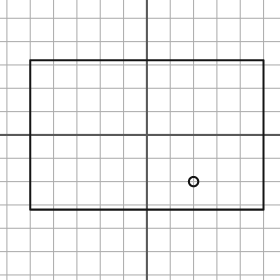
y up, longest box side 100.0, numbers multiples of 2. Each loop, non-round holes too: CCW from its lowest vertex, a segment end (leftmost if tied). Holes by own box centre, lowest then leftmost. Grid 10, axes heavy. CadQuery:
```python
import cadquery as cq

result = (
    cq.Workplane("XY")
    .moveTo(-50.0, -32.0)
    .lineTo(50.0, -32.0)
    .lineTo(50.0, 32.0)
    .lineTo(-50.0, 32.0)
    .close()
    .moveTo(20.0, -20.0)
    .circle(2.0)
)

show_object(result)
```